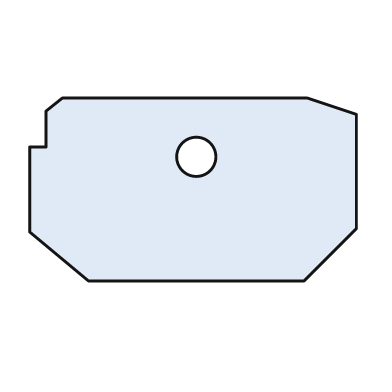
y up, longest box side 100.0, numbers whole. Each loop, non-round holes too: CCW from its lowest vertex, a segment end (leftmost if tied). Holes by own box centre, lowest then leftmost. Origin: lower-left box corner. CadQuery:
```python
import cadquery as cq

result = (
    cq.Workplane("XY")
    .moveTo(18.0, 0.0)
    .lineTo(84.0, 0.0)
    .lineTo(100.0, 16.0)
    .lineTo(100.0, 51.0)
    .lineTo(85.0, 56.0)
    .lineTo(10.0, 56.0)
    .lineTo(5.0, 52.0)
    .lineTo(5.0, 41.0)
    .lineTo(0.0, 41.0)
    .lineTo(0.0, 15.0)
    .close()
    .moveTo(51.0, 38.0)
    .circle(6.0)
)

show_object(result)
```